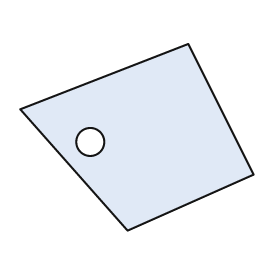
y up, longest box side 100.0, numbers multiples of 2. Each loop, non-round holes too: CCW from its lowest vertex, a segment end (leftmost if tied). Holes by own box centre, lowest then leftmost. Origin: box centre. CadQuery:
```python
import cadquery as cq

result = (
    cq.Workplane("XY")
    .moveTo(-4.0, -40.0)
    .lineTo(50.0, -16.0)
    .lineTo(22.0, 40.0)
    .lineTo(-50.0, 12.0)
    .close()
    .moveTo(-20.0, -2.0)
    .circle(6.0)
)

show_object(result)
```